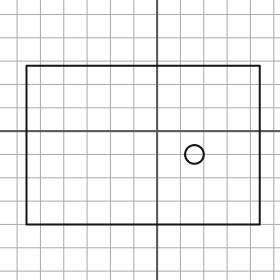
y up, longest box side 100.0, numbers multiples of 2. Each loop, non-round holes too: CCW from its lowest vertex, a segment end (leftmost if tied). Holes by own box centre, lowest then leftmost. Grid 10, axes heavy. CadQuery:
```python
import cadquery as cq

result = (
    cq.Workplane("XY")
    .moveTo(-56.0, -40.0)
    .lineTo(44.0, -40.0)
    .lineTo(44.0, 28.0)
    .lineTo(-56.0, 28.0)
    .close()
    .moveTo(16.0, -10.0)
    .circle(4.0)
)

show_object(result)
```